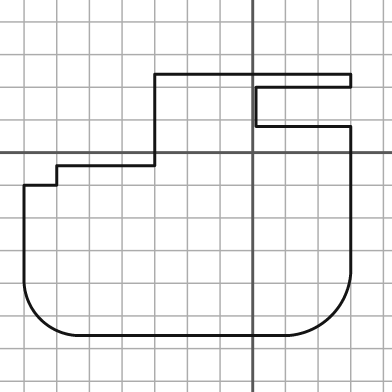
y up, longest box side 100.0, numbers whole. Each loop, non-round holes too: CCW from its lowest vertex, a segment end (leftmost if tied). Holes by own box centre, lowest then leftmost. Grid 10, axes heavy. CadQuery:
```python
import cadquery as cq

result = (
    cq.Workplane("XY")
    .moveTo(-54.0, -56.0)
    .lineTo(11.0, -56.0)
    .threePointArc((24.0, -50.0), (30.0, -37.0))
    .lineTo(30.0, 8.0)
    .lineTo(1.0, 8.0)
    .lineTo(1.0, 20.0)
    .lineTo(30.0, 20.0)
    .lineTo(30.0, 24.0)
    .lineTo(-30.0, 24.0)
    .lineTo(-30.0, -4.0)
    .lineTo(-60.0, -4.0)
    .lineTo(-60.0, -10.0)
    .lineTo(-70.0, -10.0)
    .lineTo(-70.0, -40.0)
    .threePointArc((-65.0, -51.0), (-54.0, -56.0))
    .close()
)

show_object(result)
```